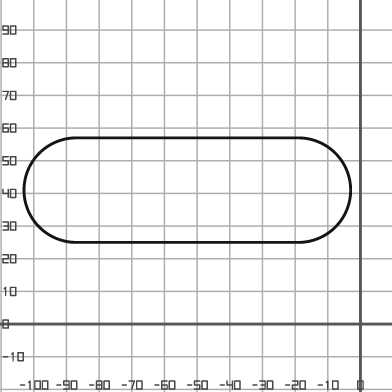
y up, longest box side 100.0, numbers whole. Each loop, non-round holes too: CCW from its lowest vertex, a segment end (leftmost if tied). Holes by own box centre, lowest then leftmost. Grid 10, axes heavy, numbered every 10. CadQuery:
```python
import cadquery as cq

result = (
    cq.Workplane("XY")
    .moveTo(-87.0, 25.0)
    .lineTo(-19.0, 25.0)
    .threePointArc((-3.0, 41.0), (-19.0, 57.0))
    .lineTo(-87.0, 57.0)
    .threePointArc((-103.0, 41.0), (-87.0, 25.0))
    .close()
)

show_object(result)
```